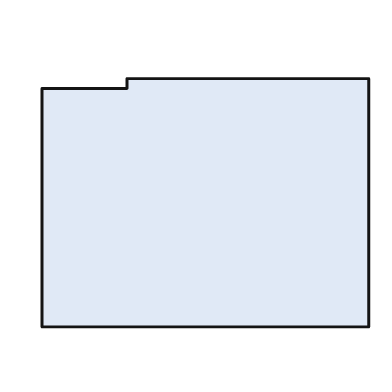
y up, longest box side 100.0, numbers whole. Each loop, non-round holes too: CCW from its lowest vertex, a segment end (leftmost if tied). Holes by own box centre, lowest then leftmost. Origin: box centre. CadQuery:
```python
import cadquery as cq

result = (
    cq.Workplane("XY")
    .moveTo(-50.0, -38.0)
    .lineTo(50.0, -38.0)
    .lineTo(50.0, 38.0)
    .lineTo(-24.0, 38.0)
    .lineTo(-24.0, 35.0)
    .lineTo(-50.0, 35.0)
    .close()
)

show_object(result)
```